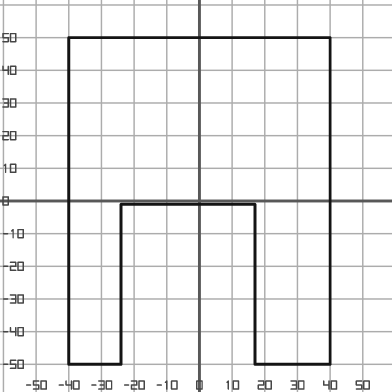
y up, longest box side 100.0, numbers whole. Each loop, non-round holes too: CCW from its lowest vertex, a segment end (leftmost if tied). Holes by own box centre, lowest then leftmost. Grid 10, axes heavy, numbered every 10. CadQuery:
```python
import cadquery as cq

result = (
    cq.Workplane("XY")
    .moveTo(-40.0, -50.0)
    .lineTo(-24.0, -50.0)
    .lineTo(-24.0, -1.0)
    .lineTo(17.0, -1.0)
    .lineTo(17.0, -50.0)
    .lineTo(40.0, -50.0)
    .lineTo(40.0, 50.0)
    .lineTo(-40.0, 50.0)
    .close()
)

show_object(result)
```